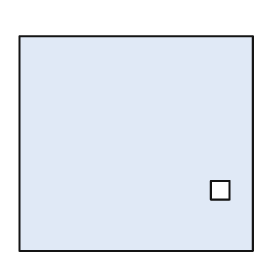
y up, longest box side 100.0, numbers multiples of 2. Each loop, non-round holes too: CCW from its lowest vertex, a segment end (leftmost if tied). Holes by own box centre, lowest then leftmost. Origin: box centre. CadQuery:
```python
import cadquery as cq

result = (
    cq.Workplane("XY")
    .moveTo(-50.0, -46.0)
    .lineTo(50.0, -46.0)
    .lineTo(50.0, 46.0)
    .lineTo(-50.0, 46.0)
    .close()
    .moveTo(32.0, -24.0)
    .lineTo(40.0, -24.0)
    .lineTo(40.0, -16.0)
    .lineTo(32.0, -16.0)
    .close()
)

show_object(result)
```